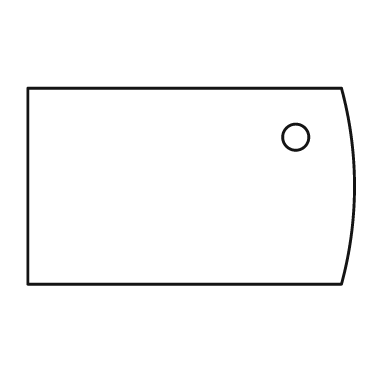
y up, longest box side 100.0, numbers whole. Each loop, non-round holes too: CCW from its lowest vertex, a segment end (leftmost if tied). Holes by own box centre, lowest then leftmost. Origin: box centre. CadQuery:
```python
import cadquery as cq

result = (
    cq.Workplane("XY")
    .moveTo(-50.0, -30.0)
    .lineTo(46.0, -30.0)
    .threePointArc((50.0, 0.0), (46.0, 30.0))
    .lineTo(-50.0, 30.0)
    .close()
    .moveTo(32.0, 15.0)
    .circle(4.0)
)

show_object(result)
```